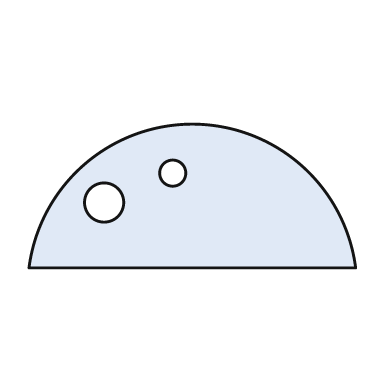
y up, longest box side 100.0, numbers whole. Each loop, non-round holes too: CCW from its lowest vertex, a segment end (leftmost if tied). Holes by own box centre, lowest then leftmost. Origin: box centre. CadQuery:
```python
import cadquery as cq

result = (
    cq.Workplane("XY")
    .moveTo(-50.0, -22.0)
    .lineTo(50.0, -22.0)
    .threePointArc((0.0, 22.0), (-50.0, -22.0))
    .close()
    .moveTo(-27.0, -2.0)
    .circle(6.0)
    .moveTo(-6.0, 7.0)
    .circle(4.0)
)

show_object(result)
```